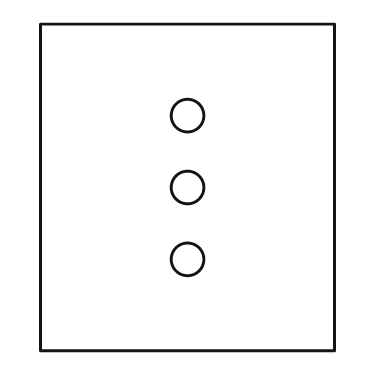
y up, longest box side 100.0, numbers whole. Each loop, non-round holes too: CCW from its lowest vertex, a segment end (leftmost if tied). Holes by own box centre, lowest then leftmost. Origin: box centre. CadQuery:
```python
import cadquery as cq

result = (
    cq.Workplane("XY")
    .moveTo(-45.0, -50.0)
    .lineTo(45.0, -50.0)
    .lineTo(45.0, 50.0)
    .lineTo(-45.0, 50.0)
    .close()
    .moveTo(0.0, -22.0)
    .circle(5.0)
    .moveTo(0.0, 0.0)
    .circle(5.0)
    .moveTo(0.0, 22.0)
    .circle(5.0)
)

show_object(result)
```